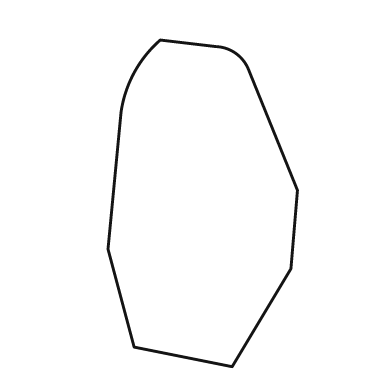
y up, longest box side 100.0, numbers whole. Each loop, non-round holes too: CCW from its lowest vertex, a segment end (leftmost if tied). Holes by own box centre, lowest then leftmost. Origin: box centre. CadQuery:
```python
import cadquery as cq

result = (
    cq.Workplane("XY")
    .moveTo(9.0, -50.0)
    .lineTo(27.0, -20.0)
    .lineTo(29.0, 4.0)
    .lineTo(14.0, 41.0)
    .threePointArc((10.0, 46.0), (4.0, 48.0))
    .lineTo(-13.0, 50.0)
    .threePointArc((-21.0, 40.0), (-25.0, 28.0))
    .lineTo(-29.0, -14.0)
    .lineTo(-21.0, -44.0)
    .close()
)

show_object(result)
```